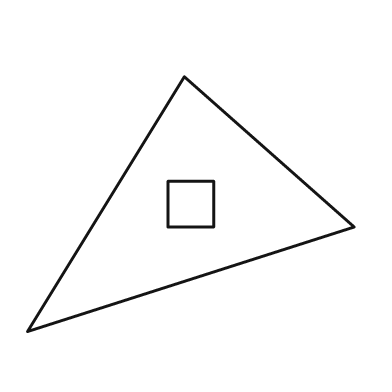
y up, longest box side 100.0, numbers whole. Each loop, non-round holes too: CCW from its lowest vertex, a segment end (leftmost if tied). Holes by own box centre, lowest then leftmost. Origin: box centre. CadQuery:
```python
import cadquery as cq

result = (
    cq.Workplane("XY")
    .moveTo(-50.0, -39.0)
    .lineTo(50.0, -7.0)
    .lineTo(-2.0, 39.0)
    .close()
    .moveTo(-7.0, -7.0)
    .lineTo(7.0, -7.0)
    .lineTo(7.0, 7.0)
    .lineTo(-7.0, 7.0)
    .close()
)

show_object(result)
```